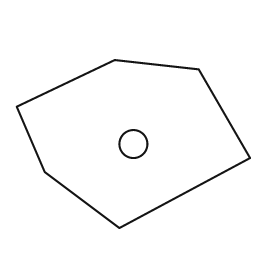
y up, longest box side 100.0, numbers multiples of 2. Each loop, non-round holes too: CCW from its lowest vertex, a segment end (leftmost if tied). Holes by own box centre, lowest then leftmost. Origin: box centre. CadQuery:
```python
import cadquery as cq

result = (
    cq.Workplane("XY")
    .moveTo(-6.0, -36.0)
    .lineTo(50.0, -6.0)
    .lineTo(28.0, 32.0)
    .lineTo(-8.0, 36.0)
    .lineTo(-50.0, 16.0)
    .lineTo(-38.0, -12.0)
    .close()
    .moveTo(0.0, 0.0)
    .circle(6.0)
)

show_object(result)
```